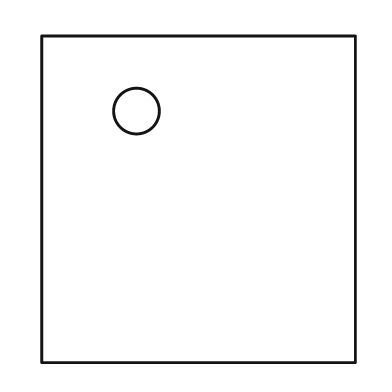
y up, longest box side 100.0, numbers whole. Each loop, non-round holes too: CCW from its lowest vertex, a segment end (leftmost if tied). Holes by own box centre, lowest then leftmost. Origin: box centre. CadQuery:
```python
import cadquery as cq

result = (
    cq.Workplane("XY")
    .moveTo(-48.0, -50.0)
    .lineTo(48.0, -50.0)
    .lineTo(48.0, 50.0)
    .lineTo(-48.0, 50.0)
    .close()
    .moveTo(-19.0, 27.0)
    .circle(7.0)
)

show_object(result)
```